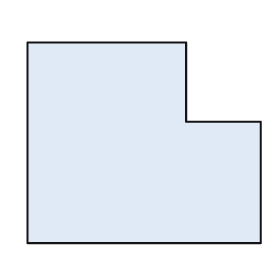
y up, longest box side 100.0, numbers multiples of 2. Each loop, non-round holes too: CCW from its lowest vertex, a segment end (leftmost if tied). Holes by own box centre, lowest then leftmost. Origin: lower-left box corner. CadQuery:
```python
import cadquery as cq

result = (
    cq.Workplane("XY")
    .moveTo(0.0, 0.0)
    .lineTo(100.0, 0.0)
    .lineTo(100.0, 52.0)
    .lineTo(68.0, 52.0)
    .lineTo(68.0, 86.0)
    .lineTo(0.0, 86.0)
    .close()
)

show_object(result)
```